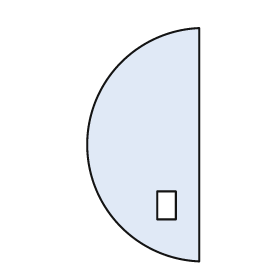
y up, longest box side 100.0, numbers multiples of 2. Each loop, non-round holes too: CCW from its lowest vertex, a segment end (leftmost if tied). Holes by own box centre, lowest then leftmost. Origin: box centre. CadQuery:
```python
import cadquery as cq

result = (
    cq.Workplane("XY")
    .moveTo(24.0, -50.0)
    .lineTo(24.0, 50.0)
    .threePointArc((-24.0, 0.0), (24.0, -50.0))
    .close()
    .moveTo(6.0, -32.0)
    .lineTo(14.0, -32.0)
    .lineTo(14.0, -20.0)
    .lineTo(6.0, -20.0)
    .close()
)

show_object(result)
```